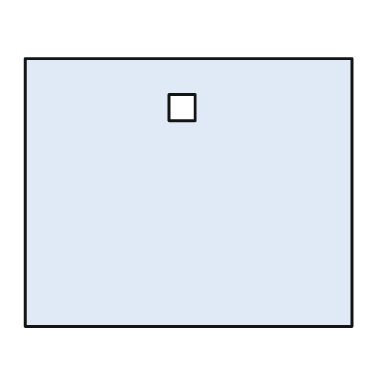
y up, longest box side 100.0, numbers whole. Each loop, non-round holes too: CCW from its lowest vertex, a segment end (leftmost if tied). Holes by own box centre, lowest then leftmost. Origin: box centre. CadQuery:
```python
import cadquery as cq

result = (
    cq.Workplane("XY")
    .moveTo(-50.0, -41.0)
    .lineTo(50.0, -41.0)
    .lineTo(50.0, 41.0)
    .lineTo(-50.0, 41.0)
    .close()
    .moveTo(-6.0, 22.0)
    .lineTo(2.0, 22.0)
    .lineTo(2.0, 30.0)
    .lineTo(-6.0, 30.0)
    .close()
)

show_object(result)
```